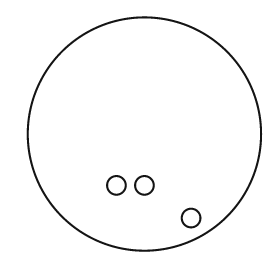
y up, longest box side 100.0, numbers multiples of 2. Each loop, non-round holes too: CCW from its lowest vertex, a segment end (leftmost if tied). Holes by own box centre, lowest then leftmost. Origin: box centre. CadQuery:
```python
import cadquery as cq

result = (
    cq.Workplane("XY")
    .moveTo(0.0, 0.0)
    .circle(50.0)
    .moveTo(20.0, -36.0)
    .circle(4.0)
    .moveTo(-12.0, -22.0)
    .circle(4.0)
    .moveTo(0.0, -22.0)
    .circle(4.0)
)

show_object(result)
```